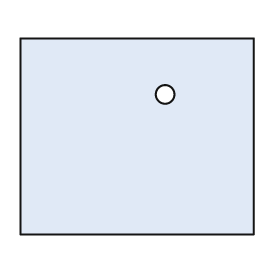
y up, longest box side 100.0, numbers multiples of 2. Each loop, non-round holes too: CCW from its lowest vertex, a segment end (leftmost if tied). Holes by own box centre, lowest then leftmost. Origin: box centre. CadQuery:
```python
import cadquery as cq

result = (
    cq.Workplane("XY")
    .moveTo(-50.0, -42.0)
    .lineTo(50.0, -42.0)
    .lineTo(50.0, 42.0)
    .lineTo(-50.0, 42.0)
    .close()
    .moveTo(12.0, 18.0)
    .circle(4.0)
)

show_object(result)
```